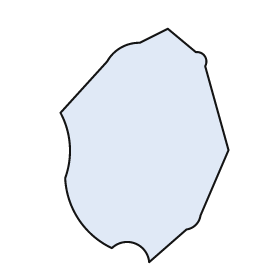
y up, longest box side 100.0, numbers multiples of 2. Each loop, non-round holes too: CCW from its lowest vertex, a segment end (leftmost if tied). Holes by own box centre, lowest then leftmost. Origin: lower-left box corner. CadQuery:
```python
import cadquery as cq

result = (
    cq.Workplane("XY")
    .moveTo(38.0, 0.0)
    .lineTo(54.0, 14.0)
    .threePointArc((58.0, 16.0), (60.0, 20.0))
    .lineTo(72.0, 48.0)
    .lineTo(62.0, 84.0)
    .threePointArc((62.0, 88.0), (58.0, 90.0))
    .lineTo(46.0, 100.0)
    .lineTo(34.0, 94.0)
    .threePointArc((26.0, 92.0), (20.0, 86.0))
    .lineTo(0.0, 64.0)
    .threePointArc((4.0, 50.0), (2.0, 36.0))
    .threePointArc((8.0, 18.0), (22.0, 6.0))
    .threePointArc((32.0, 8.0), (38.0, 0.0))
    .close()
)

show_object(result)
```